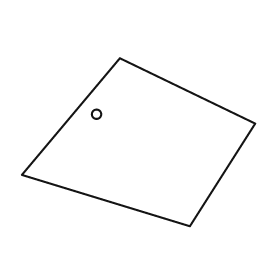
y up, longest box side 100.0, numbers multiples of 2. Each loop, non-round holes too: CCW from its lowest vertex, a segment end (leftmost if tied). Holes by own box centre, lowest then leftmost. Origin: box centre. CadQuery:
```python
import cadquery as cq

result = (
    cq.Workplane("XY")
    .moveTo(22.0, -36.0)
    .lineTo(50.0, 8.0)
    .lineTo(-8.0, 36.0)
    .lineTo(-50.0, -14.0)
    .close()
    .moveTo(-18.0, 12.0)
    .circle(2.0)
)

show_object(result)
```